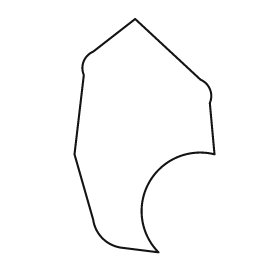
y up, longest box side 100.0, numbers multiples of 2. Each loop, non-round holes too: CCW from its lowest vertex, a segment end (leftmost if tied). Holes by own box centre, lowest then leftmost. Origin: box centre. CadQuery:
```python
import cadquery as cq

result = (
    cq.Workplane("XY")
    .moveTo(6.0, -50.0)
    .threePointArc((2.0, -20.0), (30.0, -8.0))
    .lineTo(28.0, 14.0)
    .threePointArc((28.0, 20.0), (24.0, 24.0))
    .lineTo(-4.0, 50.0)
    .lineTo(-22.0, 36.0)
    .threePointArc((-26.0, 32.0), (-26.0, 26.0))
    .lineTo(-30.0, -8.0)
    .lineTo(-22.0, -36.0)
    .threePointArc((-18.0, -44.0), (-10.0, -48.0))
    .close()
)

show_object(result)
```